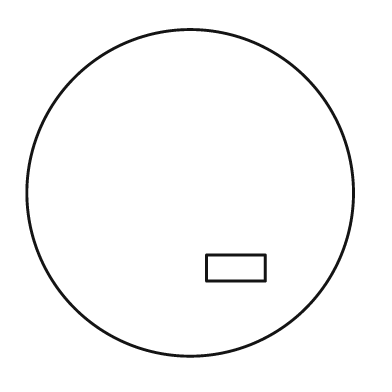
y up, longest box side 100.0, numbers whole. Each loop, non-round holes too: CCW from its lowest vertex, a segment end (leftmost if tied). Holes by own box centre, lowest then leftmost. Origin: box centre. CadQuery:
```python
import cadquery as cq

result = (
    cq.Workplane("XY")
    .moveTo(0.0, 0.0)
    .circle(50.0)
    .moveTo(5.0, -27.0)
    .lineTo(23.0, -27.0)
    .lineTo(23.0, -19.0)
    .lineTo(5.0, -19.0)
    .close()
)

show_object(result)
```